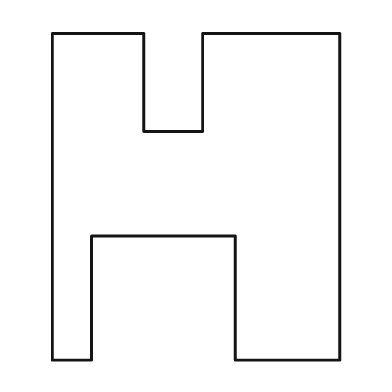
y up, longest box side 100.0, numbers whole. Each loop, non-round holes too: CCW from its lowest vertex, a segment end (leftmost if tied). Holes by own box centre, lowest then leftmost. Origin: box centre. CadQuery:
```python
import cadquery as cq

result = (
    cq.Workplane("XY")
    .moveTo(-44.0, -50.0)
    .lineTo(-32.0, -50.0)
    .lineTo(-32.0, -12.0)
    .lineTo(12.0, -12.0)
    .lineTo(12.0, -50.0)
    .lineTo(44.0, -50.0)
    .lineTo(44.0, 50.0)
    .lineTo(2.0, 50.0)
    .lineTo(2.0, 20.0)
    .lineTo(-16.0, 20.0)
    .lineTo(-16.0, 50.0)
    .lineTo(-44.0, 50.0)
    .close()
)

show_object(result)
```